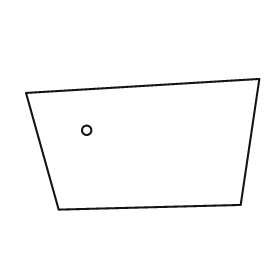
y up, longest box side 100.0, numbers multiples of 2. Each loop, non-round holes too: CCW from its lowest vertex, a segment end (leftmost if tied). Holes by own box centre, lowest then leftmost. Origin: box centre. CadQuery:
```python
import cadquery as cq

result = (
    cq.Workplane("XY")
    .moveTo(-36.0, -28.0)
    .lineTo(42.0, -26.0)
    .lineTo(50.0, 28.0)
    .lineTo(-50.0, 22.0)
    .close()
    .moveTo(-24.0, 6.0)
    .circle(2.0)
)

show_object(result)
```